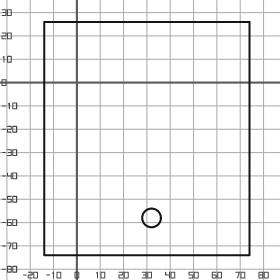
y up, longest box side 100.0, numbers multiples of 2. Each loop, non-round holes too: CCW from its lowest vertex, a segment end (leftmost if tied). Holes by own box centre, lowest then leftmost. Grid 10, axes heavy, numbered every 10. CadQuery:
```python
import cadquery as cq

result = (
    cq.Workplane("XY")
    .moveTo(-14.0, -74.0)
    .lineTo(74.0, -74.0)
    .lineTo(74.0, 26.0)
    .lineTo(-14.0, 26.0)
    .close()
    .moveTo(32.0, -58.0)
    .circle(4.0)
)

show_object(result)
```